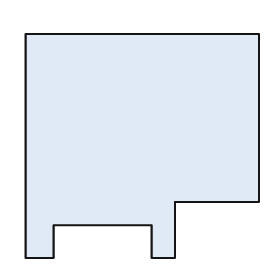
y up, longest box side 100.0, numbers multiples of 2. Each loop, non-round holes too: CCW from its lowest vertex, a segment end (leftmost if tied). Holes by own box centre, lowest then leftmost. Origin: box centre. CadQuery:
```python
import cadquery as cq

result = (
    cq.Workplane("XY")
    .moveTo(-50.0, -48.0)
    .lineTo(-38.0, -48.0)
    .lineTo(-38.0, -34.0)
    .lineTo(4.0, -34.0)
    .lineTo(4.0, -48.0)
    .lineTo(14.0, -48.0)
    .lineTo(14.0, -24.0)
    .lineTo(50.0, -24.0)
    .lineTo(50.0, 48.0)
    .lineTo(-50.0, 48.0)
    .close()
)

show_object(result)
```